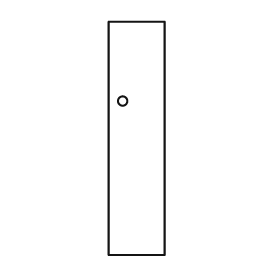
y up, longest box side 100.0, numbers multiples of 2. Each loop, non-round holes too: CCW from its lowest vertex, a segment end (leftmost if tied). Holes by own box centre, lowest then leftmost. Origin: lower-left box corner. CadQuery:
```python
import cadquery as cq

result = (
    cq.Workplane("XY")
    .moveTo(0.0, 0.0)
    .lineTo(24.0, 0.0)
    .lineTo(24.0, 100.0)
    .lineTo(0.0, 100.0)
    .close()
    .moveTo(6.0, 66.0)
    .circle(2.0)
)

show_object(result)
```